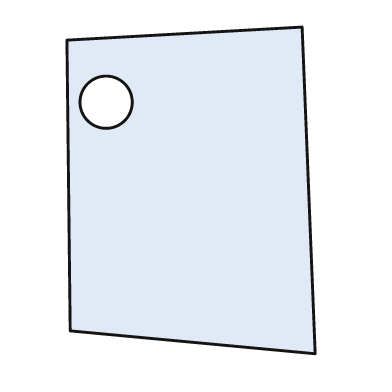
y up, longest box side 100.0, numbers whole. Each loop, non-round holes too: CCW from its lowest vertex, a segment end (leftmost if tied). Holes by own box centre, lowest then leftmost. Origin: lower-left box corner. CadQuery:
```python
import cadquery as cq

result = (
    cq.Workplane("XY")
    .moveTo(76.0, 0.0)
    .lineTo(72.0, 100.0)
    .lineTo(0.0, 96.0)
    .lineTo(1.0, 7.0)
    .close()
    .moveTo(12.0, 77.0)
    .circle(8.0)
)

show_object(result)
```